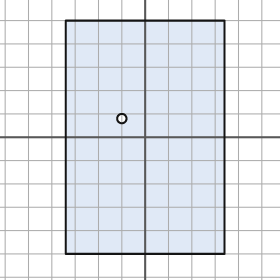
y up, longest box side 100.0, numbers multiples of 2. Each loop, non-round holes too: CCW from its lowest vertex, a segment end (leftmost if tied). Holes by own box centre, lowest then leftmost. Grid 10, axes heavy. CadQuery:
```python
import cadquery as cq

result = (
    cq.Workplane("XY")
    .moveTo(-34.0, -50.0)
    .lineTo(34.0, -50.0)
    .lineTo(34.0, 50.0)
    .lineTo(-34.0, 50.0)
    .close()
    .moveTo(-10.0, 8.0)
    .circle(2.0)
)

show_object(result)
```